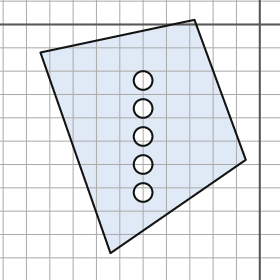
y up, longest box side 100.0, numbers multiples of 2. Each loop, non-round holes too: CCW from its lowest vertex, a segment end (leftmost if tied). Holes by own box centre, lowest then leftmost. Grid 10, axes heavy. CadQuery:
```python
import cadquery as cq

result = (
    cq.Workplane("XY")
    .moveTo(-64.0, -98.0)
    .lineTo(-6.0, -58.0)
    .lineTo(-28.0, 2.0)
    .lineTo(-94.0, -12.0)
    .close()
    .moveTo(-50.0, -72.0)
    .circle(4.0)
    .moveTo(-50.0, -60.0)
    .circle(4.0)
    .moveTo(-50.0, -48.0)
    .circle(4.0)
    .moveTo(-50.0, -36.0)
    .circle(4.0)
    .moveTo(-50.0, -24.0)
    .circle(4.0)
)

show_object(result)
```